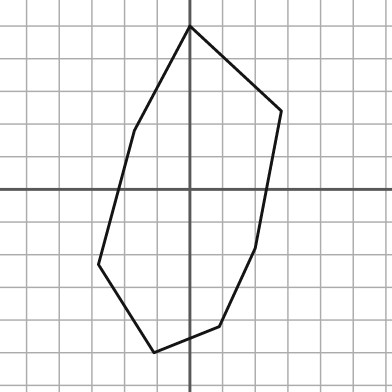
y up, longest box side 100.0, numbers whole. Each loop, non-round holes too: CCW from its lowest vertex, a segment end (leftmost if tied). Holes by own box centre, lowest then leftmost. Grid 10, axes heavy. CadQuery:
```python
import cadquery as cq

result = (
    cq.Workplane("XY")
    .moveTo(-11.0, -50.0)
    .lineTo(9.0, -42.0)
    .lineTo(20.0, -18.0)
    .lineTo(28.0, 24.0)
    .lineTo(0.0, 50.0)
    .lineTo(-17.0, 18.0)
    .lineTo(-28.0, -23.0)
    .close()
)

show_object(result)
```